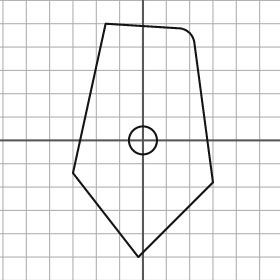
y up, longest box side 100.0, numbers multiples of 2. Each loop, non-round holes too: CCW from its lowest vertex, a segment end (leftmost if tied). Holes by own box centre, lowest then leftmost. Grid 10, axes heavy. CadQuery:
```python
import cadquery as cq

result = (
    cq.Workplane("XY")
    .moveTo(-2.0, -50.0)
    .lineTo(30.0, -18.0)
    .lineTo(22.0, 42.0)
    .threePointArc((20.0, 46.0), (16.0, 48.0))
    .lineTo(-16.0, 50.0)
    .lineTo(-30.0, -14.0)
    .close()
    .moveTo(0.0, 0.0)
    .circle(6.0)
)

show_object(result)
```